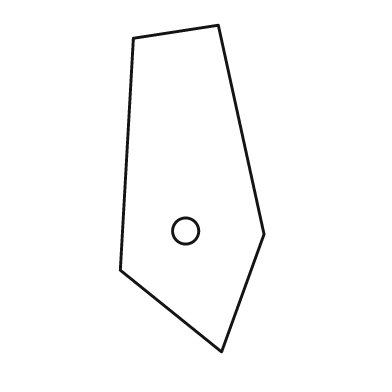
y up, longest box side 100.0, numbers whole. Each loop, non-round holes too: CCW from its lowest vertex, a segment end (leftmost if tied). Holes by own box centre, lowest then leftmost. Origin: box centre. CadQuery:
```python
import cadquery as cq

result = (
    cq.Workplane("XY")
    .moveTo(9.0, -50.0)
    .lineTo(22.0, -14.0)
    .lineTo(8.0, 50.0)
    .lineTo(-18.0, 46.0)
    .lineTo(-22.0, -25.0)
    .close()
    .moveTo(-2.0, -13.0)
    .circle(4.0)
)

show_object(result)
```